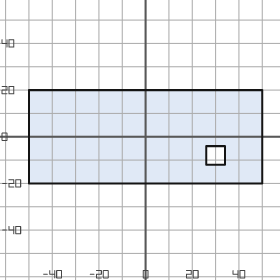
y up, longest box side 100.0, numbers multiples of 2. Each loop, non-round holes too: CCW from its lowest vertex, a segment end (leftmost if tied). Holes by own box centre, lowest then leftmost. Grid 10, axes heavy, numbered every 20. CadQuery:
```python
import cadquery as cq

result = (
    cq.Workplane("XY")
    .moveTo(-50.0, -20.0)
    .lineTo(50.0, -20.0)
    .lineTo(50.0, 20.0)
    .lineTo(-50.0, 20.0)
    .close()
    .moveTo(26.0, -12.0)
    .lineTo(34.0, -12.0)
    .lineTo(34.0, -4.0)
    .lineTo(26.0, -4.0)
    .close()
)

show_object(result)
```